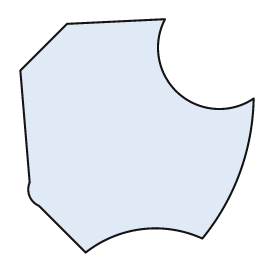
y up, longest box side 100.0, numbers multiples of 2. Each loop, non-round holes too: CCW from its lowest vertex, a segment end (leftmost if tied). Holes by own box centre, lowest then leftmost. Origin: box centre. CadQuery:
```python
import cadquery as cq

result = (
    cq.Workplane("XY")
    .moveTo(-22.0, -50.0)
    .threePointArc((2.0, -40.0), (28.0, -44.0))
    .threePointArc((44.0, -16.0), (50.0, 16.0))
    .threePointArc((18.0, 18.0), (12.0, 50.0))
    .lineTo(-30.0, 48.0)
    .lineTo(-50.0, 28.0)
    .lineTo(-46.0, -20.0)
    .threePointArc((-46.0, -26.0), (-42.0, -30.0))
    .close()
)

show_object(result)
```